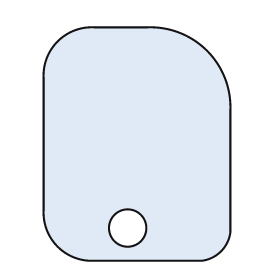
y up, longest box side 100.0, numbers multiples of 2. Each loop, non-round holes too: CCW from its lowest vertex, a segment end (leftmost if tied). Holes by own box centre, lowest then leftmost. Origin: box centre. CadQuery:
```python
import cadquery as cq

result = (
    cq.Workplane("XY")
    .moveTo(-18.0, -50.0)
    .lineTo(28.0, -50.0)
    .threePointArc((36.0, -46.0), (40.0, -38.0))
    .lineTo(40.0, 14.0)
    .threePointArc((30.0, 40.0), (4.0, 50.0))
    .lineTo(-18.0, 50.0)
    .threePointArc((-34.0, 44.0), (-40.0, 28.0))
    .lineTo(-40.0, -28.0)
    .threePointArc((-34.0, -44.0), (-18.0, -50.0))
    .close()
    .moveTo(-4.0, -36.0)
    .circle(8.0)
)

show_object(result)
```